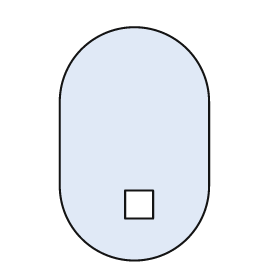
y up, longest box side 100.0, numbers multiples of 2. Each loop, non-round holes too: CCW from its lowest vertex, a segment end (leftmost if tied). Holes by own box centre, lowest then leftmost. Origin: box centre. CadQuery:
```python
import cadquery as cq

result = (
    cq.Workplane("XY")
    .moveTo(-32.0, -18.0)
    .threePointArc((0.0, -50.0), (32.0, -18.0))
    .lineTo(32.0, 18.0)
    .threePointArc((0.0, 50.0), (-32.0, 18.0))
    .close()
    .moveTo(-4.0, -32.0)
    .lineTo(8.0, -32.0)
    .lineTo(8.0, -20.0)
    .lineTo(-4.0, -20.0)
    .close()
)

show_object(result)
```